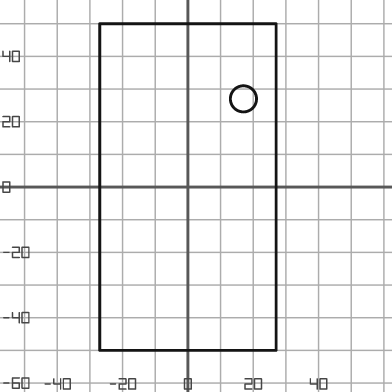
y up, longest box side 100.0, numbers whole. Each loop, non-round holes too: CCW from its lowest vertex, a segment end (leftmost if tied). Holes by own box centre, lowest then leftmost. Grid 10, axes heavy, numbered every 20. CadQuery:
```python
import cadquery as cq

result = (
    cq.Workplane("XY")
    .moveTo(-27.0, -50.0)
    .lineTo(27.0, -50.0)
    .lineTo(27.0, 50.0)
    .lineTo(-27.0, 50.0)
    .close()
    .moveTo(17.0, 27.0)
    .circle(4.0)
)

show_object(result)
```